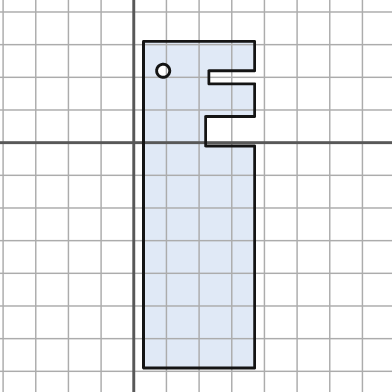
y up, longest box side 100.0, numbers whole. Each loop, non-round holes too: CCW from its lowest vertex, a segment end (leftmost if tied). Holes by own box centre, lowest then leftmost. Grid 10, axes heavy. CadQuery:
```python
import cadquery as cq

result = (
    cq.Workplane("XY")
    .moveTo(3.0, -69.0)
    .lineTo(37.0, -69.0)
    .lineTo(37.0, -1.0)
    .lineTo(22.0, -1.0)
    .lineTo(22.0, 8.0)
    .lineTo(37.0, 8.0)
    .lineTo(37.0, 18.0)
    .lineTo(23.0, 18.0)
    .lineTo(23.0, 22.0)
    .lineTo(37.0, 22.0)
    .lineTo(37.0, 31.0)
    .lineTo(3.0, 31.0)
    .close()
    .moveTo(9.0, 22.0)
    .circle(2.0)
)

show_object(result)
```